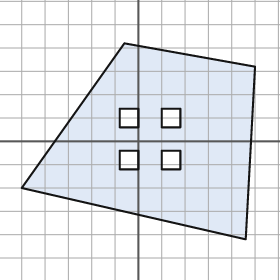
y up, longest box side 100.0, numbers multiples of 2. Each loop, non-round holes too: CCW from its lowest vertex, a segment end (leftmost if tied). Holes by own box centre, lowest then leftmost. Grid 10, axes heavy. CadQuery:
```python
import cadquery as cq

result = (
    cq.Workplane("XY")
    .moveTo(46.0, -42.0)
    .lineTo(50.0, 32.0)
    .lineTo(-6.0, 42.0)
    .lineTo(-50.0, -20.0)
    .close()
    .moveTo(-8.0, -12.0)
    .lineTo(0.0, -12.0)
    .lineTo(0.0, -4.0)
    .lineTo(-8.0, -4.0)
    .close()
    .moveTo(10.0, -12.0)
    .lineTo(18.0, -12.0)
    .lineTo(18.0, -4.0)
    .lineTo(10.0, -4.0)
    .close()
    .moveTo(-8.0, 6.0)
    .lineTo(0.0, 6.0)
    .lineTo(0.0, 14.0)
    .lineTo(-8.0, 14.0)
    .close()
    .moveTo(10.0, 6.0)
    .lineTo(18.0, 6.0)
    .lineTo(18.0, 14.0)
    .lineTo(10.0, 14.0)
    .close()
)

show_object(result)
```